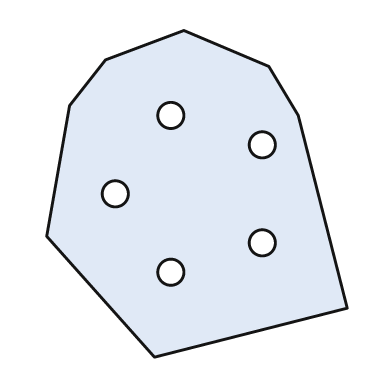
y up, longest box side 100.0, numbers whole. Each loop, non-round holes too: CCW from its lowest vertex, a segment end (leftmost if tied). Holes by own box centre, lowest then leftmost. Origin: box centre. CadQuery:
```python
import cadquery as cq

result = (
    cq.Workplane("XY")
    .moveTo(-13.0, -50.0)
    .lineTo(46.0, -35.0)
    .lineTo(31.0, 24.0)
    .lineTo(22.0, 39.0)
    .lineTo(-4.0, 50.0)
    .lineTo(-28.0, 41.0)
    .lineTo(-39.0, 27.0)
    .lineTo(-46.0, -13.0)
    .close()
    .moveTo(-8.0, -24.0)
    .circle(4.0)
    .moveTo(20.0, -15.0)
    .circle(4.0)
    .moveTo(-25.0, 0.0)
    .circle(4.0)
    .moveTo(20.0, 15.0)
    .circle(4.0)
    .moveTo(-8.0, 24.0)
    .circle(4.0)
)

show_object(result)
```